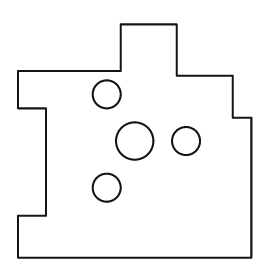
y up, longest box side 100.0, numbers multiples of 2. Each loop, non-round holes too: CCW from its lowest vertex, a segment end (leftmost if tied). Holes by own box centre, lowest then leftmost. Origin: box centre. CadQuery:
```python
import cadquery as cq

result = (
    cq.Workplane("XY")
    .moveTo(-50.0, -50.0)
    .lineTo(50.0, -50.0)
    .lineTo(50.0, 10.0)
    .lineTo(42.0, 10.0)
    .lineTo(42.0, 28.0)
    .lineTo(18.0, 28.0)
    .lineTo(18.0, 50.0)
    .lineTo(-6.0, 50.0)
    .lineTo(-6.0, 30.0)
    .lineTo(-50.0, 30.0)
    .lineTo(-50.0, 14.0)
    .lineTo(-38.0, 14.0)
    .lineTo(-38.0, -32.0)
    .lineTo(-50.0, -32.0)
    .close()
    .moveTo(-12.0, -20.0)
    .circle(6.0)
    .moveTo(0.0, 0.0)
    .circle(8.0)
    .moveTo(22.0, 0.0)
    .circle(6.0)
    .moveTo(-12.0, 20.0)
    .circle(6.0)
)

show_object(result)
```